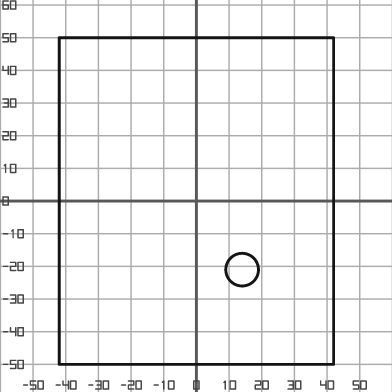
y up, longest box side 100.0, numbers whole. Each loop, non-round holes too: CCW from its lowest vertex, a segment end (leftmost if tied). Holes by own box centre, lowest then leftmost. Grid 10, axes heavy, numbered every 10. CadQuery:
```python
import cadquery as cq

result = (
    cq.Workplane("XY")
    .moveTo(-42.0, -50.0)
    .lineTo(42.0, -50.0)
    .lineTo(42.0, 50.0)
    .lineTo(-42.0, 50.0)
    .close()
    .moveTo(14.0, -21.0)
    .circle(5.0)
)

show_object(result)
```